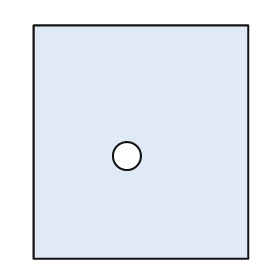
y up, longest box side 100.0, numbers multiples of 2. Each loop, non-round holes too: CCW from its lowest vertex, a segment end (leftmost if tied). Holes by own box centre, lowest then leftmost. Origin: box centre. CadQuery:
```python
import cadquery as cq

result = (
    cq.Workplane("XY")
    .moveTo(-46.0, -50.0)
    .lineTo(46.0, -50.0)
    .lineTo(46.0, 50.0)
    .lineTo(-46.0, 50.0)
    .close()
    .moveTo(-6.0, -6.0)
    .circle(6.0)
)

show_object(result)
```